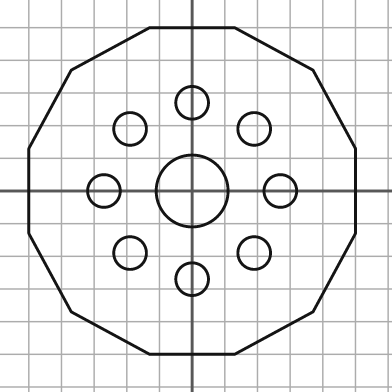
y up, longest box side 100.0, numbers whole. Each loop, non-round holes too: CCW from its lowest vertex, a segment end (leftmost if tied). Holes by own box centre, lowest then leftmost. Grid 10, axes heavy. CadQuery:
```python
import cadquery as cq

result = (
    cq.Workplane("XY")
    .moveTo(-13.0, -50.0)
    .lineTo(13.0, -50.0)
    .lineTo(37.0, -37.0)
    .lineTo(50.0, -13.0)
    .lineTo(50.0, 13.0)
    .lineTo(37.0, 37.0)
    .lineTo(13.0, 50.0)
    .lineTo(-13.0, 50.0)
    .lineTo(-37.0, 37.0)
    .lineTo(-50.0, 13.0)
    .lineTo(-50.0, -13.0)
    .lineTo(-37.0, -37.0)
    .close()
    .moveTo(0.0, -27.0)
    .circle(5.0)
    .moveTo(-19.0, -19.0)
    .circle(5.0)
    .moveTo(19.0, -19.0)
    .circle(5.0)
    .moveTo(-27.0, 0.0)
    .circle(5.0)
    .moveTo(0.0, 0.0)
    .circle(11.0)
    .moveTo(27.0, 0.0)
    .circle(5.0)
    .moveTo(-19.0, 19.0)
    .circle(5.0)
    .moveTo(19.0, 19.0)
    .circle(5.0)
    .moveTo(0.0, 27.0)
    .circle(5.0)
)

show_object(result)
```